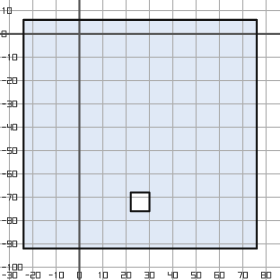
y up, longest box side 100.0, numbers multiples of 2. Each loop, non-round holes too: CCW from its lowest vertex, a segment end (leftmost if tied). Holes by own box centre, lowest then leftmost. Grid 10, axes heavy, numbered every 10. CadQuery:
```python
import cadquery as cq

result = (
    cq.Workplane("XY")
    .moveTo(-24.0, -92.0)
    .lineTo(76.0, -92.0)
    .lineTo(76.0, 6.0)
    .lineTo(-24.0, 6.0)
    .close()
    .moveTo(22.0, -76.0)
    .lineTo(30.0, -76.0)
    .lineTo(30.0, -68.0)
    .lineTo(22.0, -68.0)
    .close()
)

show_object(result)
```